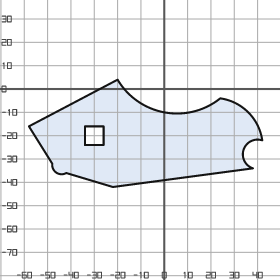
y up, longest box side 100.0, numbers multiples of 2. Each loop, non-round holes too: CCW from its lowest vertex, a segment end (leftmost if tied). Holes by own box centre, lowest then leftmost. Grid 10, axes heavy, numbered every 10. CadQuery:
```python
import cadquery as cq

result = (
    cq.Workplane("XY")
    .moveTo(-22.0, -42.0)
    .lineTo(38.0, -34.0)
    .threePointArc((34.0, -26.0), (42.0, -22.0))
    .threePointArc((36.0, -10.0), (24.0, -4.0))
    .threePointArc((0.0, -10.0), (-20.0, 4.0))
    .lineTo(-58.0, -16.0)
    .lineTo(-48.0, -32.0)
    .threePointArc((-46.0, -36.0), (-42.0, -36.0))
    .close()
    .moveTo(-34.0, -24.0)
    .lineTo(-26.0, -24.0)
    .lineTo(-26.0, -16.0)
    .lineTo(-34.0, -16.0)
    .close()
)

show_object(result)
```